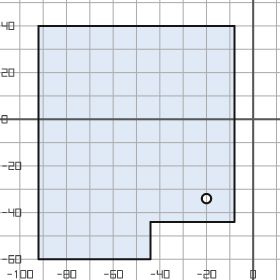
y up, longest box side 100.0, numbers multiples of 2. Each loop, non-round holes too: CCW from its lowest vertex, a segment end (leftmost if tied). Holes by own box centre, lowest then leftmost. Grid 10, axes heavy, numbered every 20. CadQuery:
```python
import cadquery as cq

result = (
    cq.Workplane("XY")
    .moveTo(-92.0, -60.0)
    .lineTo(-44.0, -60.0)
    .lineTo(-44.0, -44.0)
    .lineTo(-8.0, -44.0)
    .lineTo(-8.0, 40.0)
    .lineTo(-92.0, 40.0)
    .close()
    .moveTo(-20.0, -34.0)
    .circle(2.0)
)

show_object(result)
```